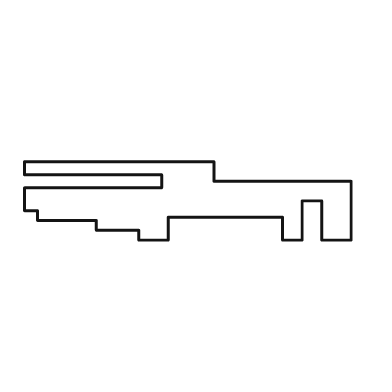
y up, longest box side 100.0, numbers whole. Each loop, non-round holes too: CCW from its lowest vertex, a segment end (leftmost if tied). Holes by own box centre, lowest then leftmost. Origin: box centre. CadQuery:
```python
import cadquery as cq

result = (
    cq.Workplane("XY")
    .moveTo(-15.0, -12.0)
    .lineTo(-6.0, -12.0)
    .lineTo(-6.0, -5.0)
    .lineTo(29.0, -5.0)
    .lineTo(29.0, -12.0)
    .lineTo(35.0, -12.0)
    .lineTo(35.0, 0.0)
    .lineTo(41.0, 0.0)
    .lineTo(41.0, -12.0)
    .lineTo(50.0, -12.0)
    .lineTo(50.0, 6.0)
    .lineTo(8.0, 6.0)
    .lineTo(8.0, 12.0)
    .lineTo(-50.0, 12.0)
    .lineTo(-50.0, 8.0)
    .lineTo(-8.0, 8.0)
    .lineTo(-8.0, 4.0)
    .lineTo(-50.0, 4.0)
    .lineTo(-50.0, -3.0)
    .lineTo(-46.0, -3.0)
    .lineTo(-46.0, -6.0)
    .lineTo(-28.0, -6.0)
    .lineTo(-28.0, -9.0)
    .lineTo(-15.0, -9.0)
    .close()
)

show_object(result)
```